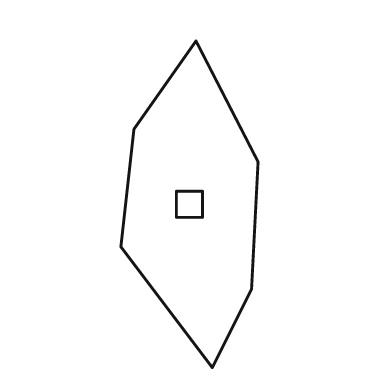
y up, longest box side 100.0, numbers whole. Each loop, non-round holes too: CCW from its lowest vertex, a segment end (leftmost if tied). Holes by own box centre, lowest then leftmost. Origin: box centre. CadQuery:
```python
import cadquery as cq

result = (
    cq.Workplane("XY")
    .moveTo(7.0, -50.0)
    .lineTo(19.0, -26.0)
    .lineTo(21.0, 13.0)
    .lineTo(2.0, 50.0)
    .lineTo(-17.0, 23.0)
    .lineTo(-21.0, -13.0)
    .close()
    .moveTo(-4.0, -4.0)
    .lineTo(4.0, -4.0)
    .lineTo(4.0, 4.0)
    .lineTo(-4.0, 4.0)
    .close()
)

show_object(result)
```